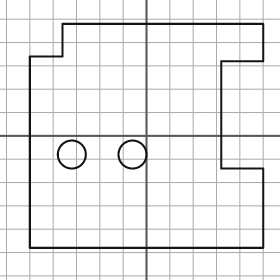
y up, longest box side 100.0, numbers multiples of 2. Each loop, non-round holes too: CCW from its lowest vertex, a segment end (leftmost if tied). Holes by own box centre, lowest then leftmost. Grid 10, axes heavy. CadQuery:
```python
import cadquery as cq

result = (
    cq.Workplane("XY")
    .moveTo(-50.0, -48.0)
    .lineTo(50.0, -48.0)
    .lineTo(50.0, -14.0)
    .lineTo(32.0, -14.0)
    .lineTo(32.0, 32.0)
    .lineTo(50.0, 32.0)
    .lineTo(50.0, 48.0)
    .lineTo(-36.0, 48.0)
    .lineTo(-36.0, 34.0)
    .lineTo(-50.0, 34.0)
    .close()
    .moveTo(-32.0, -8.0)
    .circle(6.0)
    .moveTo(-6.0, -8.0)
    .circle(6.0)
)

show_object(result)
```